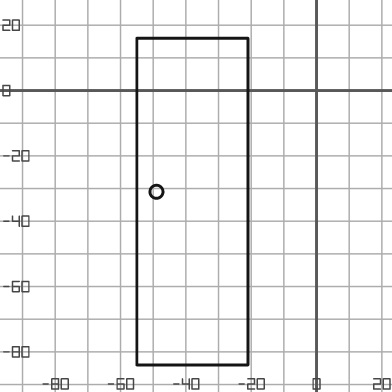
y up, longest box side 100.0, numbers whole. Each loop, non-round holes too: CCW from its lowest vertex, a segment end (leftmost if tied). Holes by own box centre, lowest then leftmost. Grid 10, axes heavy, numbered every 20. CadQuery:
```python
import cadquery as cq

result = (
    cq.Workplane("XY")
    .moveTo(-55.0, -84.0)
    .lineTo(-21.0, -84.0)
    .lineTo(-21.0, 16.0)
    .lineTo(-55.0, 16.0)
    .close()
    .moveTo(-49.0, -31.0)
    .circle(2.0)
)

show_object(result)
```